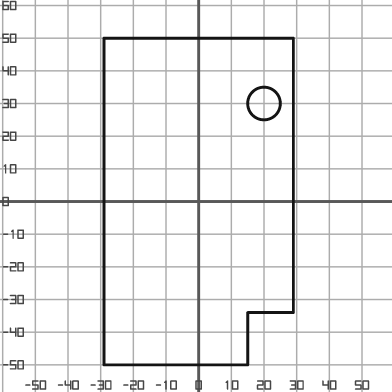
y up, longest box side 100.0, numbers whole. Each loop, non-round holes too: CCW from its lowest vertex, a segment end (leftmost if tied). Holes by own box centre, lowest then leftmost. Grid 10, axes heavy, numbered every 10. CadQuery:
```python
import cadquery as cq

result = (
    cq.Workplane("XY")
    .moveTo(-29.0, -50.0)
    .lineTo(15.0, -50.0)
    .lineTo(15.0, -34.0)
    .lineTo(29.0, -34.0)
    .lineTo(29.0, 50.0)
    .lineTo(-29.0, 50.0)
    .close()
    .moveTo(20.0, 30.0)
    .circle(5.0)
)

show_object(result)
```